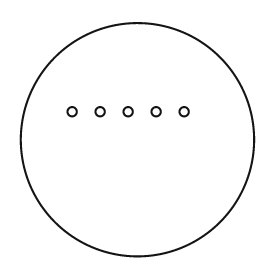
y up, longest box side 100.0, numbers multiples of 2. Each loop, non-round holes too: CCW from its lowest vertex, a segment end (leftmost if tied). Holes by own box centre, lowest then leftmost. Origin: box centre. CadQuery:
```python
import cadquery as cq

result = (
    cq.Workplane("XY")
    .moveTo(0.0, 0.0)
    .circle(50.0)
    .moveTo(-28.0, 12.0)
    .circle(2.0)
    .moveTo(-16.0, 12.0)
    .circle(2.0)
    .moveTo(-4.0, 12.0)
    .circle(2.0)
    .moveTo(8.0, 12.0)
    .circle(2.0)
    .moveTo(20.0, 12.0)
    .circle(2.0)
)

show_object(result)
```